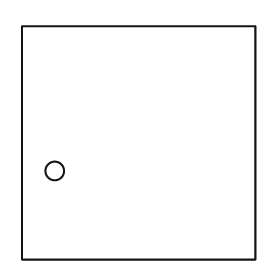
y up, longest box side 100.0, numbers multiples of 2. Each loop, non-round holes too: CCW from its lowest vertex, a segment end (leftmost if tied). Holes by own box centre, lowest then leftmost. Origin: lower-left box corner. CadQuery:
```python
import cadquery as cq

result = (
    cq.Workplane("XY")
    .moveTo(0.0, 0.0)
    .lineTo(100.0, 0.0)
    .lineTo(100.0, 100.0)
    .lineTo(0.0, 100.0)
    .close()
    .moveTo(14.0, 38.0)
    .circle(4.0)
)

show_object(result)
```